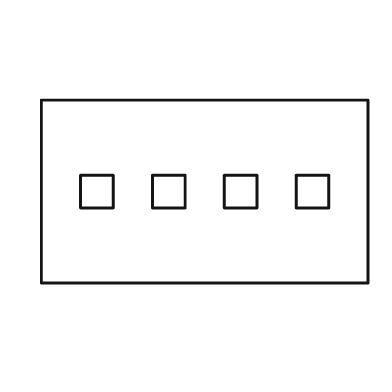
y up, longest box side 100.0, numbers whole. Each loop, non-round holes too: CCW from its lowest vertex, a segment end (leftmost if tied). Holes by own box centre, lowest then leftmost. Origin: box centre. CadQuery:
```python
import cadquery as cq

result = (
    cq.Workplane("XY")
    .moveTo(-50.0, -28.0)
    .lineTo(50.0, -28.0)
    .lineTo(50.0, 28.0)
    .lineTo(-50.0, 28.0)
    .close()
    .moveTo(-38.0, -5.0)
    .lineTo(-28.0, -5.0)
    .lineTo(-28.0, 5.0)
    .lineTo(-38.0, 5.0)
    .close()
    .moveTo(-16.0, -5.0)
    .lineTo(-6.0, -5.0)
    .lineTo(-6.0, 5.0)
    .lineTo(-16.0, 5.0)
    .close()
    .moveTo(6.0, -5.0)
    .lineTo(16.0, -5.0)
    .lineTo(16.0, 5.0)
    .lineTo(6.0, 5.0)
    .close()
    .moveTo(28.0, -5.0)
    .lineTo(38.0, -5.0)
    .lineTo(38.0, 5.0)
    .lineTo(28.0, 5.0)
    .close()
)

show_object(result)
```